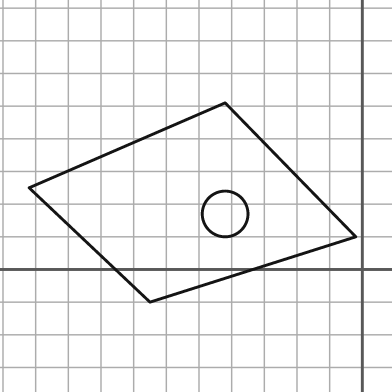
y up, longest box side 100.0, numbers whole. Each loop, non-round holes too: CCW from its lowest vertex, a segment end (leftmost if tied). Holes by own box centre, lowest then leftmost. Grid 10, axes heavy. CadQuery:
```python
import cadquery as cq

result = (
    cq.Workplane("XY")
    .moveTo(-65.0, -10.0)
    .lineTo(-2.0, 10.0)
    .lineTo(-42.0, 51.0)
    .lineTo(-102.0, 25.0)
    .close()
    .moveTo(-42.0, 17.0)
    .circle(7.0)
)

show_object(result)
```